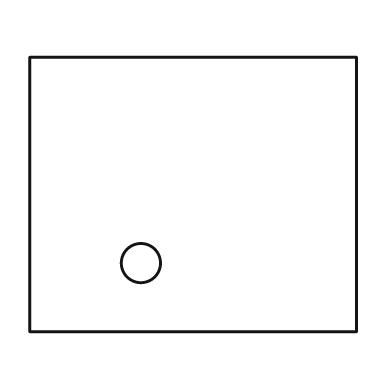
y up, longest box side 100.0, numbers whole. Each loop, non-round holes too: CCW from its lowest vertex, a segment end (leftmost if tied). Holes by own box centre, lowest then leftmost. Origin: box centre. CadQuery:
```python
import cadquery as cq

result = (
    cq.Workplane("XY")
    .moveTo(-50.0, -42.0)
    .lineTo(50.0, -42.0)
    .lineTo(50.0, 42.0)
    .lineTo(-50.0, 42.0)
    .close()
    .moveTo(-16.0, -21.0)
    .circle(6.0)
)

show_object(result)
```